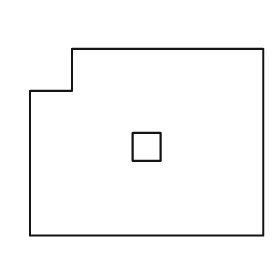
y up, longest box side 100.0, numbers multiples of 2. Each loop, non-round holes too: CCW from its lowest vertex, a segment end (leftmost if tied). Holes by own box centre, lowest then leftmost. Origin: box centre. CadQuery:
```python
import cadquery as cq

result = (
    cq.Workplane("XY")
    .moveTo(-50.0, -40.0)
    .lineTo(50.0, -40.0)
    .lineTo(50.0, 40.0)
    .lineTo(-32.0, 40.0)
    .lineTo(-32.0, 22.0)
    .lineTo(-50.0, 22.0)
    .close()
    .moveTo(-6.0, -8.0)
    .lineTo(6.0, -8.0)
    .lineTo(6.0, 4.0)
    .lineTo(-6.0, 4.0)
    .close()
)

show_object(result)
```